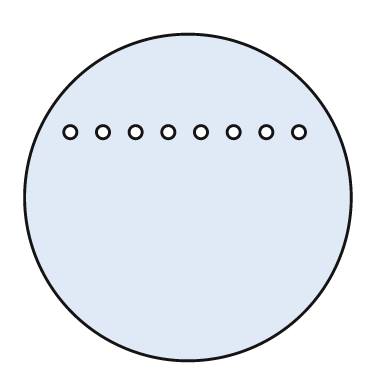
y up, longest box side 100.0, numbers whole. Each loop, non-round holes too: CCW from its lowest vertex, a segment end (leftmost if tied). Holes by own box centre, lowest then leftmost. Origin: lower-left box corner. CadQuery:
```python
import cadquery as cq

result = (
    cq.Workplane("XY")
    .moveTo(50.0, 50.0)
    .circle(50.0)
    .moveTo(14.0, 70.0)
    .circle(2.0)
    .moveTo(24.0, 70.0)
    .circle(2.0)
    .moveTo(34.0, 70.0)
    .circle(2.0)
    .moveTo(44.0, 70.0)
    .circle(2.0)
    .moveTo(54.0, 70.0)
    .circle(2.0)
    .moveTo(64.0, 70.0)
    .circle(2.0)
    .moveTo(74.0, 70.0)
    .circle(2.0)
    .moveTo(84.0, 70.0)
    .circle(2.0)
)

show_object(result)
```